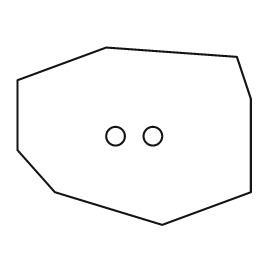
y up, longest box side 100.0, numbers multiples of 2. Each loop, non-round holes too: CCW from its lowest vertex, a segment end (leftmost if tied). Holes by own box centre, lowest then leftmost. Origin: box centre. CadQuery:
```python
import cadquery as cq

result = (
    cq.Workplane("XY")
    .moveTo(12.0, -38.0)
    .lineTo(50.0, -24.0)
    .lineTo(50.0, 16.0)
    .lineTo(44.0, 34.0)
    .lineTo(-12.0, 38.0)
    .lineTo(-50.0, 24.0)
    .lineTo(-50.0, -6.0)
    .lineTo(-34.0, -24.0)
    .close()
    .moveTo(-8.0, 0.0)
    .circle(4.0)
    .moveTo(8.0, 0.0)
    .circle(4.0)
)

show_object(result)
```